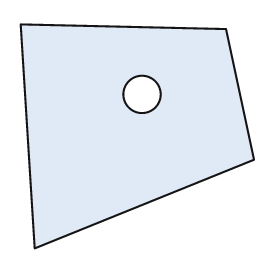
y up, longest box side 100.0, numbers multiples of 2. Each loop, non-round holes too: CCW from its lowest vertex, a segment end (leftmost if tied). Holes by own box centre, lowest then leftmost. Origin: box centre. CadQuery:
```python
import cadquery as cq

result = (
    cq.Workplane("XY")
    .moveTo(-44.0, -48.0)
    .lineTo(50.0, -10.0)
    .lineTo(38.0, 46.0)
    .lineTo(-50.0, 48.0)
    .close()
    .moveTo(2.0, 18.0)
    .circle(8.0)
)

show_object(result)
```